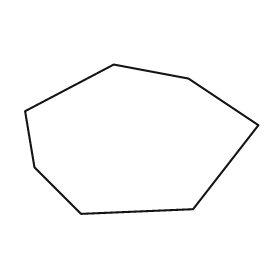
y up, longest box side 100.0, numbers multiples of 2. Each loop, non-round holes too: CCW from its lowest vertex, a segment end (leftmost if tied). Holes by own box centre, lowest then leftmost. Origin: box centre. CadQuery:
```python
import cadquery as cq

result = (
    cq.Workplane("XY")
    .moveTo(-26.0, -32.0)
    .lineTo(22.0, -30.0)
    .lineTo(50.0, 6.0)
    .lineTo(20.0, 26.0)
    .lineTo(-12.0, 32.0)
    .lineTo(-50.0, 12.0)
    .lineTo(-46.0, -12.0)
    .close()
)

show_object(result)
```